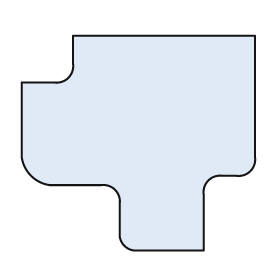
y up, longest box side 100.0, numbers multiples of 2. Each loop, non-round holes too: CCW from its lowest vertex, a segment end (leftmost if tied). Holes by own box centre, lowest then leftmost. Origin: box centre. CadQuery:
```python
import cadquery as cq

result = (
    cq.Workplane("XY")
    .moveTo(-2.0, -46.0)
    .lineTo(28.0, -46.0)
    .lineTo(28.0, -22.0)
    .threePointArc((30.0, -16.0), (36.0, -14.0))
    .lineTo(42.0, -14.0)
    .threePointArc((48.0, -12.0), (50.0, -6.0))
    .lineTo(50.0, 46.0)
    .lineTo(-28.0, 46.0)
    .lineTo(-28.0, 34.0)
    .threePointArc((-30.0, 28.0), (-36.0, 26.0))
    .lineTo(-50.0, 26.0)
    .lineTo(-50.0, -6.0)
    .threePointArc((-46.0, -14.0), (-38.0, -18.0))
    .lineTo(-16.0, -18.0)
    .threePointArc((-10.0, -20.0), (-8.0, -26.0))
    .lineTo(-8.0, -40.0)
    .threePointArc((-6.0, -44.0), (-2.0, -46.0))
    .close()
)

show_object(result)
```